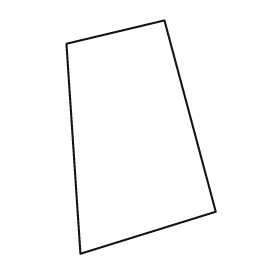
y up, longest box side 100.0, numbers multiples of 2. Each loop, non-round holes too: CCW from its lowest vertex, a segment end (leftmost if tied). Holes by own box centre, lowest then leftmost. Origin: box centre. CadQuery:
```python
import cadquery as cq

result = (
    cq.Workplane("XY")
    .moveTo(-26.0, -50.0)
    .lineTo(32.0, -32.0)
    .lineTo(10.0, 50.0)
    .lineTo(-32.0, 40.0)
    .close()
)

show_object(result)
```